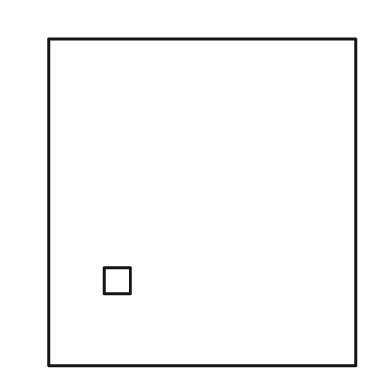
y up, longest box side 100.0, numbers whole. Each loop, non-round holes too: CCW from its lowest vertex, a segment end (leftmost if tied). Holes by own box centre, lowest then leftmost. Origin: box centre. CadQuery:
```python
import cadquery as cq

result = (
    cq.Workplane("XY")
    .moveTo(-47.0, -50.0)
    .lineTo(47.0, -50.0)
    .lineTo(47.0, 50.0)
    .lineTo(-47.0, 50.0)
    .close()
    .moveTo(-30.0, -28.0)
    .lineTo(-22.0, -28.0)
    .lineTo(-22.0, -20.0)
    .lineTo(-30.0, -20.0)
    .close()
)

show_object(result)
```